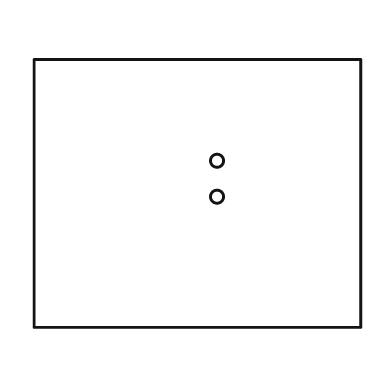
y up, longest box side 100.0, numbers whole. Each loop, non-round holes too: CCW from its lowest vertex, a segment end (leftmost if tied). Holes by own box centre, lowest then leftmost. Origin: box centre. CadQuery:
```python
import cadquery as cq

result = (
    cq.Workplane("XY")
    .moveTo(-50.0, -41.0)
    .lineTo(50.0, -41.0)
    .lineTo(50.0, 41.0)
    .lineTo(-50.0, 41.0)
    .close()
    .moveTo(6.0, -1.0)
    .circle(2.0)
    .moveTo(6.0, 10.0)
    .circle(2.0)
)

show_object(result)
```